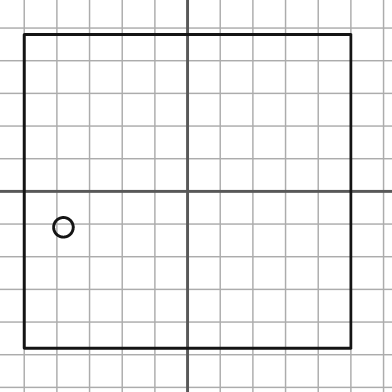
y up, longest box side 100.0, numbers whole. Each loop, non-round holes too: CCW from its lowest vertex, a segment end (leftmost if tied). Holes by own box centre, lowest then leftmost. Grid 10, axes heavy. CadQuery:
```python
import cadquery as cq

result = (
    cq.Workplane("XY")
    .moveTo(-50.0, -48.0)
    .lineTo(50.0, -48.0)
    .lineTo(50.0, 48.0)
    .lineTo(-50.0, 48.0)
    .close()
    .moveTo(-38.0, -11.0)
    .circle(3.0)
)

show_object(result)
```